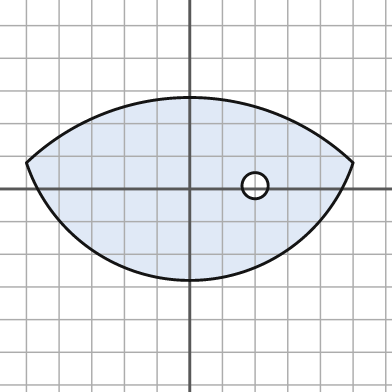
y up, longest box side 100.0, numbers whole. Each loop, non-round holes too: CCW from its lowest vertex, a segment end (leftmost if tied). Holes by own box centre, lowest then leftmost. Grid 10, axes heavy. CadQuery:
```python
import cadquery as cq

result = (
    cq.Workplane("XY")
    .moveTo(-50.0, 8.0)
    .threePointArc((0.0, -28.0), (50.0, 8.0))
    .threePointArc((0.0, 28.0), (-50.0, 8.0))
    .close()
    .moveTo(20.0, 1.0)
    .circle(4.0)
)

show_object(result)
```